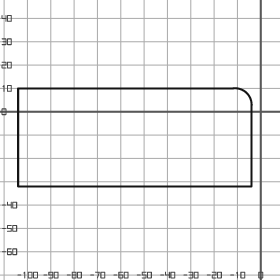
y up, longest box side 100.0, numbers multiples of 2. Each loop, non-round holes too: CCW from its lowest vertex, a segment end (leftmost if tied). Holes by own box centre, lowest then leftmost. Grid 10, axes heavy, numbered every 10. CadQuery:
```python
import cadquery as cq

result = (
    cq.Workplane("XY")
    .moveTo(-104.0, -32.0)
    .lineTo(-4.0, -32.0)
    .lineTo(-4.0, 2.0)
    .threePointArc((-6.0, 8.0), (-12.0, 10.0))
    .lineTo(-104.0, 10.0)
    .close()
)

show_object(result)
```